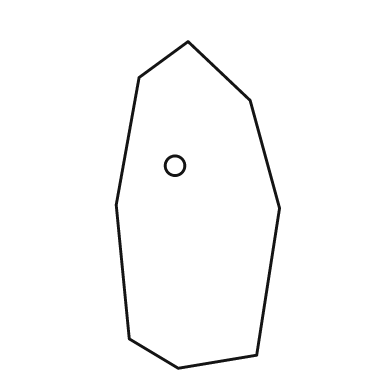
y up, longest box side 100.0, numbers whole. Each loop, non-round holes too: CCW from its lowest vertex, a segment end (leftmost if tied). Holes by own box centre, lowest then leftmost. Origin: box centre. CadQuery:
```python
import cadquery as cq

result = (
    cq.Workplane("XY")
    .moveTo(-6.0, -50.0)
    .lineTo(18.0, -46.0)
    .lineTo(25.0, -1.0)
    .lineTo(16.0, 32.0)
    .lineTo(-3.0, 50.0)
    .lineTo(-18.0, 39.0)
    .lineTo(-25.0, 0.0)
    .lineTo(-21.0, -41.0)
    .close()
    .moveTo(-7.0, 12.0)
    .circle(3.0)
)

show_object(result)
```